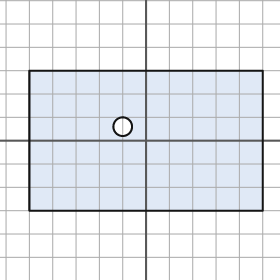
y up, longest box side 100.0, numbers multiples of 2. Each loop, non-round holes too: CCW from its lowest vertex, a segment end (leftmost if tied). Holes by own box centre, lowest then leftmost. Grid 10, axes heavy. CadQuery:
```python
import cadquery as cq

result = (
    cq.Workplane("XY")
    .moveTo(-50.0, -30.0)
    .lineTo(50.0, -30.0)
    .lineTo(50.0, 30.0)
    .lineTo(-50.0, 30.0)
    .close()
    .moveTo(-10.0, 6.0)
    .circle(4.0)
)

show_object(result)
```